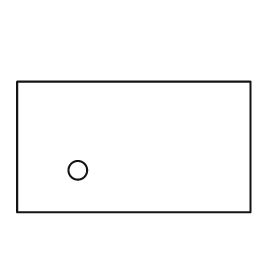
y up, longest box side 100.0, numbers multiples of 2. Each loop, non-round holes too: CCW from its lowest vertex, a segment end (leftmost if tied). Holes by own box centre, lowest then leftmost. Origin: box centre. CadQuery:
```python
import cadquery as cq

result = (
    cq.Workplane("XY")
    .moveTo(-50.0, -28.0)
    .lineTo(50.0, -28.0)
    .lineTo(50.0, 28.0)
    .lineTo(-50.0, 28.0)
    .close()
    .moveTo(-24.0, -10.0)
    .circle(4.0)
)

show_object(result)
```